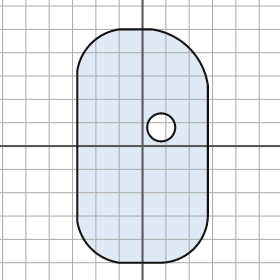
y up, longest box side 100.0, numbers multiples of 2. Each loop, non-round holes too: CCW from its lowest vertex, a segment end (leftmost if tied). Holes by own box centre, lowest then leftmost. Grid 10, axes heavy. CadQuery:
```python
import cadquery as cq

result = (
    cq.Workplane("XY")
    .moveTo(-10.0, -50.0)
    .lineTo(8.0, -50.0)
    .threePointArc((22.0, -44.0), (28.0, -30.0))
    .lineTo(28.0, 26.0)
    .threePointArc((20.0, 42.0), (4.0, 50.0))
    .lineTo(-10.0, 50.0)
    .threePointArc((-22.0, 44.0), (-28.0, 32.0))
    .lineTo(-28.0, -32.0)
    .threePointArc((-22.0, -44.0), (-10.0, -50.0))
    .close()
    .moveTo(8.0, 8.0)
    .circle(6.0)
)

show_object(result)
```